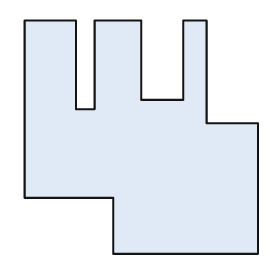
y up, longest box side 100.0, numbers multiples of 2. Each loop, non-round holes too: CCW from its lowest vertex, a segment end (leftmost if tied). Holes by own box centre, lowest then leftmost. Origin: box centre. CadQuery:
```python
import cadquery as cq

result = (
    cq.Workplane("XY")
    .moveTo(-12.0, -50.0)
    .lineTo(50.0, -50.0)
    .lineTo(50.0, 6.0)
    .lineTo(28.0, 6.0)
    .lineTo(28.0, 50.0)
    .lineTo(18.0, 50.0)
    .lineTo(18.0, 16.0)
    .lineTo(0.0, 16.0)
    .lineTo(0.0, 50.0)
    .lineTo(-20.0, 50.0)
    .lineTo(-20.0, 12.0)
    .lineTo(-28.0, 12.0)
    .lineTo(-28.0, 50.0)
    .lineTo(-50.0, 50.0)
    .lineTo(-50.0, -26.0)
    .lineTo(-12.0, -26.0)
    .close()
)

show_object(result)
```